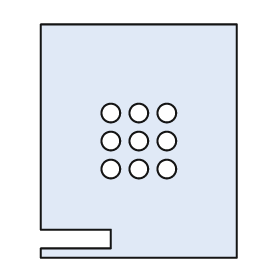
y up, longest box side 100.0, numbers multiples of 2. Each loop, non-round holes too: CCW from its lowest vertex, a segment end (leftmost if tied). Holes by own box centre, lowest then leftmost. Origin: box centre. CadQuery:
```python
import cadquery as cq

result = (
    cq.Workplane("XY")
    .moveTo(-42.0, -50.0)
    .lineTo(42.0, -50.0)
    .lineTo(42.0, 50.0)
    .lineTo(-42.0, 50.0)
    .lineTo(-42.0, -38.0)
    .lineTo(-12.0, -38.0)
    .lineTo(-12.0, -46.0)
    .lineTo(-42.0, -46.0)
    .close()
    .moveTo(-12.0, -12.0)
    .circle(4.0)
    .moveTo(0.0, -12.0)
    .circle(4.0)
    .moveTo(12.0, -12.0)
    .circle(4.0)
    .moveTo(-12.0, 0.0)
    .circle(4.0)
    .moveTo(0.0, 0.0)
    .circle(4.0)
    .moveTo(12.0, 0.0)
    .circle(4.0)
    .moveTo(-12.0, 12.0)
    .circle(4.0)
    .moveTo(0.0, 12.0)
    .circle(4.0)
    .moveTo(12.0, 12.0)
    .circle(4.0)
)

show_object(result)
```